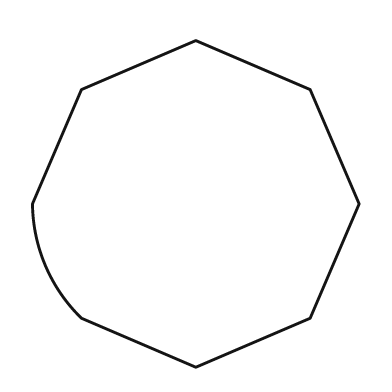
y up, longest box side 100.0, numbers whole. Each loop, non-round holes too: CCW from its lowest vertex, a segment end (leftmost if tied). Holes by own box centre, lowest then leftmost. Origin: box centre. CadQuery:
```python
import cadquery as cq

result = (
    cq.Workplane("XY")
    .moveTo(0.0, -50.0)
    .lineTo(35.0, -35.0)
    .lineTo(50.0, 0.0)
    .lineTo(35.0, 35.0)
    .lineTo(0.0, 50.0)
    .lineTo(-35.0, 35.0)
    .lineTo(-50.0, 0.0)
    .threePointArc((-46.0, -19.0), (-35.0, -35.0))
    .close()
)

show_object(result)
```